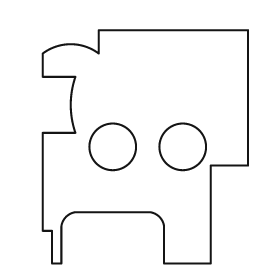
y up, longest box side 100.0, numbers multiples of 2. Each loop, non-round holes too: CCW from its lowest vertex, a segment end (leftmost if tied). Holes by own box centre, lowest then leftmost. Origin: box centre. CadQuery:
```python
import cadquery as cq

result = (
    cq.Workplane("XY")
    .moveTo(-40.0, -50.0)
    .lineTo(-36.0, -50.0)
    .lineTo(-36.0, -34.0)
    .threePointArc((-34.0, -30.0), (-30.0, -28.0))
    .lineTo(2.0, -28.0)
    .threePointArc((6.0, -30.0), (8.0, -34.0))
    .lineTo(8.0, -50.0)
    .lineTo(28.0, -50.0)
    .lineTo(28.0, -8.0)
    .lineTo(44.0, -8.0)
    .lineTo(44.0, 50.0)
    .lineTo(-20.0, 50.0)
    .lineTo(-20.0, 40.0)
    .threePointArc((-32.0, 44.0), (-44.0, 40.0))
    .lineTo(-44.0, 30.0)
    .lineTo(-30.0, 30.0)
    .threePointArc((-32.0, 18.0), (-30.0, 6.0))
    .lineTo(-44.0, 6.0)
    .lineTo(-44.0, -36.0)
    .lineTo(-40.0, -36.0)
    .close()
    .moveTo(-14.0, 0.0)
    .circle(10.0)
    .moveTo(16.0, 0.0)
    .circle(10.0)
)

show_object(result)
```